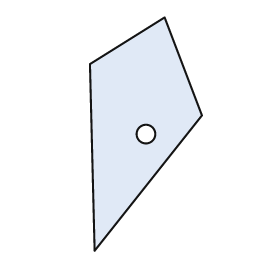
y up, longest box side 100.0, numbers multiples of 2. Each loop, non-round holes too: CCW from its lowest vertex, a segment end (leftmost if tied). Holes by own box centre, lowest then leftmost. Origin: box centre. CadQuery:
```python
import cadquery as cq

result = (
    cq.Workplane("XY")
    .moveTo(-22.0, -50.0)
    .lineTo(24.0, 8.0)
    .lineTo(8.0, 50.0)
    .lineTo(-24.0, 30.0)
    .close()
    .moveTo(0.0, 0.0)
    .circle(4.0)
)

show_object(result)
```